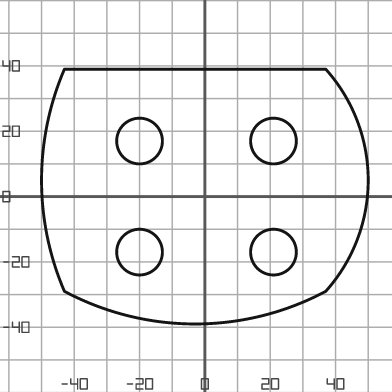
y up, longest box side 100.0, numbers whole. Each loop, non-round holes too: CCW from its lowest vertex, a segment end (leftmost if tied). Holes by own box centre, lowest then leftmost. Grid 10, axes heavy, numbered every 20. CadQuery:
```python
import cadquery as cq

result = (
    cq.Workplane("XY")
    .moveTo(-43.0, -29.0)
    .threePointArc((-3.0, -39.0), (37.0, -29.0))
    .threePointArc((50.0, 5.0), (37.0, 39.0))
    .lineTo(-43.0, 39.0)
    .threePointArc((-50.0, 5.0), (-43.0, -29.0))
    .close()
    .moveTo(-20.0, -17.0)
    .circle(7.0)
    .moveTo(21.0, -17.0)
    .circle(7.0)
    .moveTo(-20.0, 17.0)
    .circle(7.0)
    .moveTo(21.0, 17.0)
    .circle(7.0)
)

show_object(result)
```